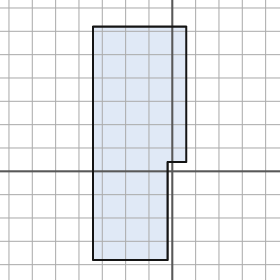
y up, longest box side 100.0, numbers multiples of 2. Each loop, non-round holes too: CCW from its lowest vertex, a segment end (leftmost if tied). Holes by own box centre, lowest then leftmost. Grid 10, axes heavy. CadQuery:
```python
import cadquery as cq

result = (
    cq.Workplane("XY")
    .moveTo(-34.0, -38.0)
    .lineTo(-2.0, -38.0)
    .lineTo(-2.0, 4.0)
    .lineTo(6.0, 4.0)
    .lineTo(6.0, 62.0)
    .lineTo(-34.0, 62.0)
    .close()
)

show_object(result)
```